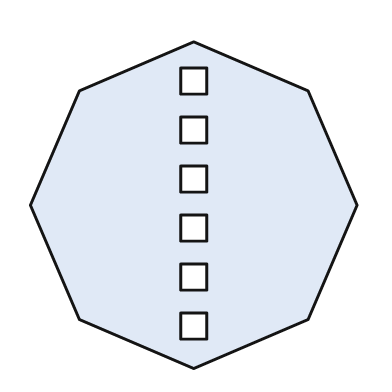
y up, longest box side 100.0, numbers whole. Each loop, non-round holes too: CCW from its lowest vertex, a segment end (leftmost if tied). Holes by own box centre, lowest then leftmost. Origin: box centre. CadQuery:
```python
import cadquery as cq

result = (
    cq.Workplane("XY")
    .moveTo(0.0, -50.0)
    .lineTo(35.0, -35.0)
    .lineTo(50.0, 0.0)
    .lineTo(35.0, 35.0)
    .lineTo(0.0, 50.0)
    .lineTo(-35.0, 35.0)
    .lineTo(-50.0, 0.0)
    .lineTo(-35.0, -35.0)
    .close()
    .moveTo(-4.0, -41.0)
    .lineTo(4.0, -41.0)
    .lineTo(4.0, -33.0)
    .lineTo(-4.0, -33.0)
    .close()
    .moveTo(-4.0, -26.0)
    .lineTo(4.0, -26.0)
    .lineTo(4.0, -18.0)
    .lineTo(-4.0, -18.0)
    .close()
    .moveTo(-4.0, -11.0)
    .lineTo(4.0, -11.0)
    .lineTo(4.0, -3.0)
    .lineTo(-4.0, -3.0)
    .close()
    .moveTo(-4.0, 4.0)
    .lineTo(4.0, 4.0)
    .lineTo(4.0, 12.0)
    .lineTo(-4.0, 12.0)
    .close()
    .moveTo(-4.0, 19.0)
    .lineTo(4.0, 19.0)
    .lineTo(4.0, 27.0)
    .lineTo(-4.0, 27.0)
    .close()
    .moveTo(-4.0, 34.0)
    .lineTo(4.0, 34.0)
    .lineTo(4.0, 42.0)
    .lineTo(-4.0, 42.0)
    .close()
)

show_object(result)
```